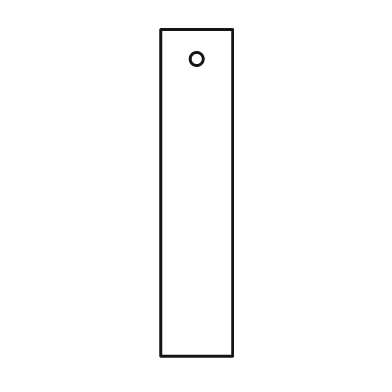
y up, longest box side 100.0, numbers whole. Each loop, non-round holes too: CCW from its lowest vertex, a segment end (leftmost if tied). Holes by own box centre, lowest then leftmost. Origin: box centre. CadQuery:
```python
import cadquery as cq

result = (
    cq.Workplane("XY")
    .moveTo(-11.0, -50.0)
    .lineTo(11.0, -50.0)
    .lineTo(11.0, 50.0)
    .lineTo(-11.0, 50.0)
    .close()
    .moveTo(0.0, 41.0)
    .circle(2.0)
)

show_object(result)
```